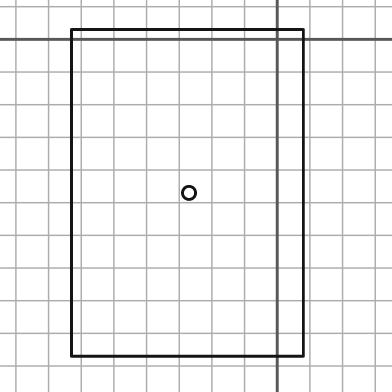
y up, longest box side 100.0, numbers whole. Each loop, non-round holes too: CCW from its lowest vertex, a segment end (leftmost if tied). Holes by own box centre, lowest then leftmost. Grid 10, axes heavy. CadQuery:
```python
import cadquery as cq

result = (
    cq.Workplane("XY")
    .moveTo(-63.0, -97.0)
    .lineTo(8.0, -97.0)
    .lineTo(8.0, 3.0)
    .lineTo(-63.0, 3.0)
    .close()
    .moveTo(-27.0, -47.0)
    .circle(2.0)
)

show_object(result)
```